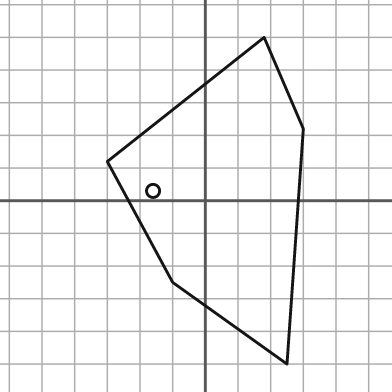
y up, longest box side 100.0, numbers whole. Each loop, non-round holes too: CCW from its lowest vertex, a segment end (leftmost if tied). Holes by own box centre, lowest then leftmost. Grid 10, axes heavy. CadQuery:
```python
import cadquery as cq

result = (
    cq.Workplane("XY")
    .moveTo(25.0, -50.0)
    .lineTo(30.0, 22.0)
    .lineTo(18.0, 50.0)
    .lineTo(-30.0, 12.0)
    .lineTo(-10.0, -25.0)
    .close()
    .moveTo(-16.0, 3.0)
    .circle(2.0)
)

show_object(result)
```